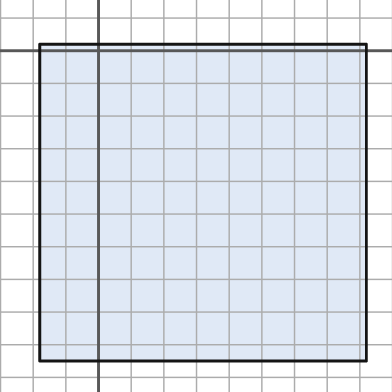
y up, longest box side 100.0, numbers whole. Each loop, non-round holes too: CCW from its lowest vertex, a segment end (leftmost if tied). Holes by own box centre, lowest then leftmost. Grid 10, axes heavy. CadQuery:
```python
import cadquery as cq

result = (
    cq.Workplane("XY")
    .moveTo(-18.0, -95.0)
    .lineTo(82.0, -95.0)
    .lineTo(82.0, 2.0)
    .lineTo(-18.0, 2.0)
    .close()
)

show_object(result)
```